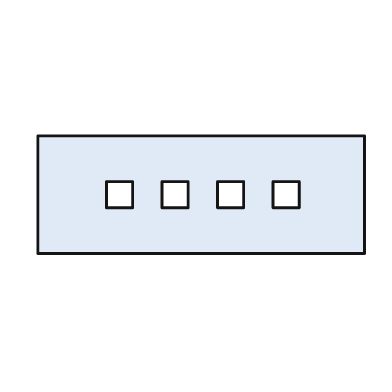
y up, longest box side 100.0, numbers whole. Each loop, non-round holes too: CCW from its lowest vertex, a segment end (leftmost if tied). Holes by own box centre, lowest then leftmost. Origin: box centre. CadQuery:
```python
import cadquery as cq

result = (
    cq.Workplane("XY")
    .moveTo(-50.0, -18.0)
    .lineTo(50.0, -18.0)
    .lineTo(50.0, 18.0)
    .lineTo(-50.0, 18.0)
    .close()
    .moveTo(-29.0, -4.0)
    .lineTo(-21.0, -4.0)
    .lineTo(-21.0, 4.0)
    .lineTo(-29.0, 4.0)
    .close()
    .moveTo(-12.0, -4.0)
    .lineTo(-4.0, -4.0)
    .lineTo(-4.0, 4.0)
    .lineTo(-12.0, 4.0)
    .close()
    .moveTo(5.0, -4.0)
    .lineTo(13.0, -4.0)
    .lineTo(13.0, 4.0)
    .lineTo(5.0, 4.0)
    .close()
    .moveTo(22.0, -4.0)
    .lineTo(30.0, -4.0)
    .lineTo(30.0, 4.0)
    .lineTo(22.0, 4.0)
    .close()
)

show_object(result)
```